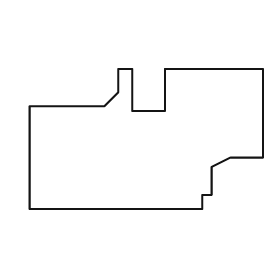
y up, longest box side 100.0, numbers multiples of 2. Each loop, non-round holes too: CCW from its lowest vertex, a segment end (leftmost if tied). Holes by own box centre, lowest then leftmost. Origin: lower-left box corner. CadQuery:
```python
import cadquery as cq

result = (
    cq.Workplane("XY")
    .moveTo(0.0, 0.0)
    .lineTo(74.0, 0.0)
    .lineTo(74.0, 6.0)
    .lineTo(78.0, 6.0)
    .lineTo(78.0, 18.0)
    .lineTo(86.0, 22.0)
    .lineTo(100.0, 22.0)
    .lineTo(100.0, 60.0)
    .lineTo(58.0, 60.0)
    .lineTo(58.0, 42.0)
    .lineTo(44.0, 42.0)
    .lineTo(44.0, 60.0)
    .lineTo(38.0, 60.0)
    .lineTo(38.0, 50.0)
    .lineTo(32.0, 44.0)
    .lineTo(0.0, 44.0)
    .close()
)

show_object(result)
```